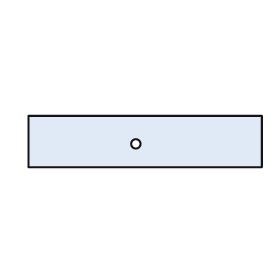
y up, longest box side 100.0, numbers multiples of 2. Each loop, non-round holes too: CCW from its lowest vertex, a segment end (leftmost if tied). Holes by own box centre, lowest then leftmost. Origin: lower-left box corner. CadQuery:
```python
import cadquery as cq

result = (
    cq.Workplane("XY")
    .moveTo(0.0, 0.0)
    .lineTo(100.0, 0.0)
    .lineTo(100.0, 22.0)
    .lineTo(0.0, 22.0)
    .close()
    .moveTo(46.0, 10.0)
    .circle(2.0)
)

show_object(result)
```